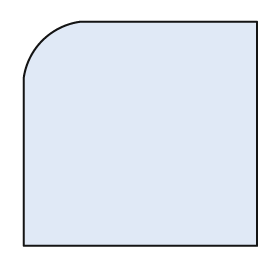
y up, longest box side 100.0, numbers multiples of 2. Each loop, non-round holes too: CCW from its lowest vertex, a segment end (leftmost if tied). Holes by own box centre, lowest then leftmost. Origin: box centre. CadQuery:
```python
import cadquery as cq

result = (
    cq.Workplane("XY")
    .moveTo(-50.0, -48.0)
    .lineTo(50.0, -48.0)
    .lineTo(50.0, 48.0)
    .lineTo(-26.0, 48.0)
    .threePointArc((-42.0, 40.0), (-50.0, 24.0))
    .close()
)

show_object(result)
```